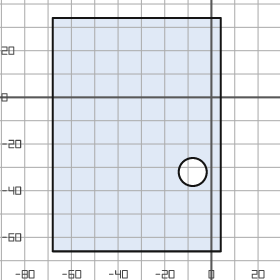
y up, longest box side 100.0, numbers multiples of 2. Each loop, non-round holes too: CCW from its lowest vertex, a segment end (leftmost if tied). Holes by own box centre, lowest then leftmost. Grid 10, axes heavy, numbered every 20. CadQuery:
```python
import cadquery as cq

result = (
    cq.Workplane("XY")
    .moveTo(-68.0, -66.0)
    .lineTo(4.0, -66.0)
    .lineTo(4.0, 34.0)
    .lineTo(-68.0, 34.0)
    .close()
    .moveTo(-8.0, -32.0)
    .circle(6.0)
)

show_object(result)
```